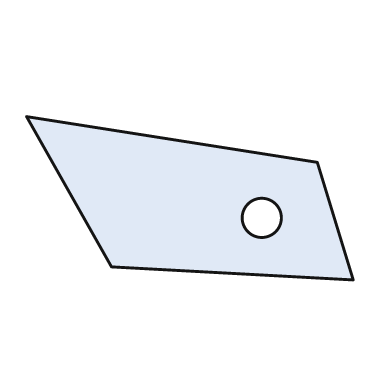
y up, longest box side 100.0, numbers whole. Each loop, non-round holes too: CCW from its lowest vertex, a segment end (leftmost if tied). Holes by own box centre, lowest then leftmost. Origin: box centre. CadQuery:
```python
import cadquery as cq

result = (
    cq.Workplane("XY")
    .moveTo(50.0, -25.0)
    .lineTo(39.0, 11.0)
    .lineTo(-50.0, 25.0)
    .lineTo(-24.0, -21.0)
    .close()
    .moveTo(22.0, -6.0)
    .circle(6.0)
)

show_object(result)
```